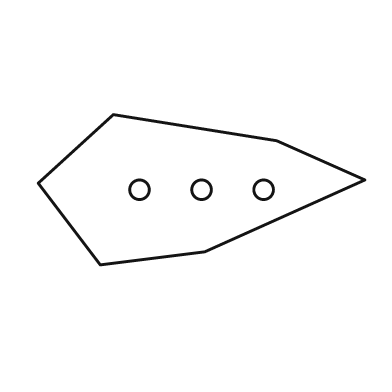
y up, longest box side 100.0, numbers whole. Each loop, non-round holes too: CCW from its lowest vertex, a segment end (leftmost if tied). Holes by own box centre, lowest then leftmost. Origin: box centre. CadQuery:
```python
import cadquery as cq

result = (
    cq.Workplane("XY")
    .moveTo(-31.0, -23.0)
    .lineTo(1.0, -19.0)
    .lineTo(50.0, 3.0)
    .lineTo(23.0, 15.0)
    .lineTo(-27.0, 23.0)
    .lineTo(-50.0, 2.0)
    .close()
    .moveTo(-19.0, 0.0)
    .circle(3.0)
    .moveTo(0.0, 0.0)
    .circle(3.0)
    .moveTo(19.0, 0.0)
    .circle(3.0)
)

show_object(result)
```